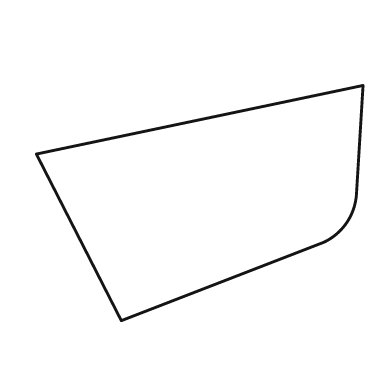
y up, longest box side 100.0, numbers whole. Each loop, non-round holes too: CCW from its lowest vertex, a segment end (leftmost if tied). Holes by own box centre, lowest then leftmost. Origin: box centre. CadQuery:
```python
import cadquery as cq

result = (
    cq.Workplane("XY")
    .moveTo(-24.0, -36.0)
    .lineTo(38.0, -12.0)
    .threePointArc((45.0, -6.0), (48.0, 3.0))
    .lineTo(50.0, 36.0)
    .lineTo(-50.0, 15.0)
    .close()
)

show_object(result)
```